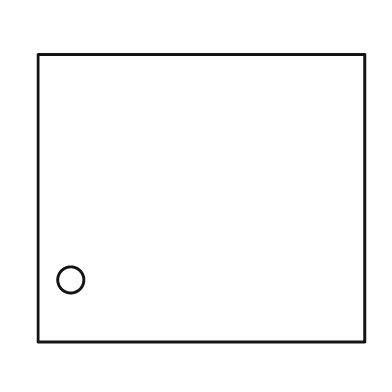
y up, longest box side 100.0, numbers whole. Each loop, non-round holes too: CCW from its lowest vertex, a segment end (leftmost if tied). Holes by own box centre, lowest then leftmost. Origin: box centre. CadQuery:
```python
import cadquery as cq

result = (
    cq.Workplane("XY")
    .moveTo(-50.0, -44.0)
    .lineTo(50.0, -44.0)
    .lineTo(50.0, 44.0)
    .lineTo(-50.0, 44.0)
    .close()
    .moveTo(-40.0, -25.0)
    .circle(4.0)
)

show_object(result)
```